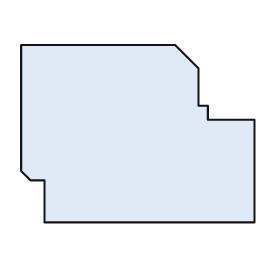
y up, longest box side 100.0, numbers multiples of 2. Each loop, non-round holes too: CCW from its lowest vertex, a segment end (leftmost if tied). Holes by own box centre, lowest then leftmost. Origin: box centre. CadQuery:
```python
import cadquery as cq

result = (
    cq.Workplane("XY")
    .moveTo(-40.0, -38.0)
    .lineTo(50.0, -38.0)
    .lineTo(50.0, 6.0)
    .lineTo(30.0, 6.0)
    .lineTo(30.0, 12.0)
    .lineTo(26.0, 12.0)
    .lineTo(26.0, 28.0)
    .lineTo(16.0, 38.0)
    .lineTo(-50.0, 38.0)
    .lineTo(-50.0, -16.0)
    .lineTo(-46.0, -20.0)
    .lineTo(-40.0, -20.0)
    .close()
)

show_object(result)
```